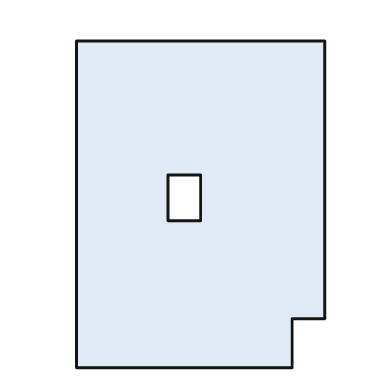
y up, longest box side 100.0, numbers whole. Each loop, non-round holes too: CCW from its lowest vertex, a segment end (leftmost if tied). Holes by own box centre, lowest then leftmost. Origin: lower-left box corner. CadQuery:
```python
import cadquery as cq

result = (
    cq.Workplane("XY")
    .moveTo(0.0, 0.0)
    .lineTo(66.0, 0.0)
    .lineTo(66.0, 15.0)
    .lineTo(76.0, 15.0)
    .lineTo(76.0, 100.0)
    .lineTo(0.0, 100.0)
    .close()
    .moveTo(28.0, 45.0)
    .lineTo(38.0, 45.0)
    .lineTo(38.0, 59.0)
    .lineTo(28.0, 59.0)
    .close()
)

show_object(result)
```